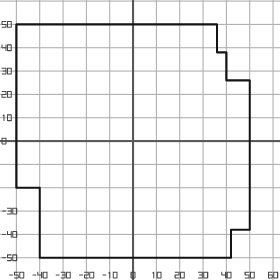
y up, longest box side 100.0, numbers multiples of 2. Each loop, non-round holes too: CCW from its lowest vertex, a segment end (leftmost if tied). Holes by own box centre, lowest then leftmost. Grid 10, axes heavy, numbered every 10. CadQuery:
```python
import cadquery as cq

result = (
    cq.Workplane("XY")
    .moveTo(-40.0, -50.0)
    .lineTo(42.0, -50.0)
    .lineTo(42.0, -38.0)
    .lineTo(50.0, -38.0)
    .lineTo(50.0, 26.0)
    .lineTo(40.0, 26.0)
    .lineTo(40.0, 38.0)
    .lineTo(36.0, 38.0)
    .lineTo(36.0, 50.0)
    .lineTo(-50.0, 50.0)
    .lineTo(-50.0, -20.0)
    .lineTo(-40.0, -20.0)
    .close()
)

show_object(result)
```